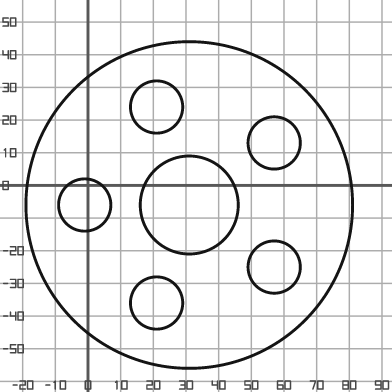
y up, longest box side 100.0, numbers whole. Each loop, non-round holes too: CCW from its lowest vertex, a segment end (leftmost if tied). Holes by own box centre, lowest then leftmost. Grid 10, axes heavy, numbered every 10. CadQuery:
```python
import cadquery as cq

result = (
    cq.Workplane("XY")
    .moveTo(31.0, -6.0)
    .circle(50.0)
    .moveTo(21.0, -36.0)
    .circle(8.0)
    .moveTo(57.0, -25.0)
    .circle(8.0)
    .moveTo(-1.0, -6.0)
    .circle(8.0)
    .moveTo(31.0, -6.0)
    .circle(15.0)
    .moveTo(57.0, 13.0)
    .circle(8.0)
    .moveTo(21.0, 24.0)
    .circle(8.0)
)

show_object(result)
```